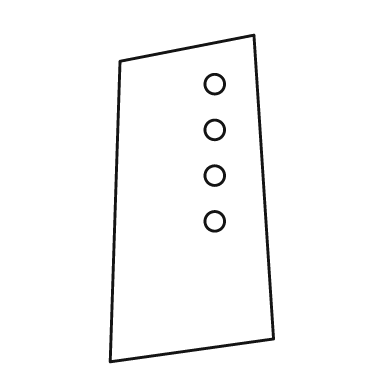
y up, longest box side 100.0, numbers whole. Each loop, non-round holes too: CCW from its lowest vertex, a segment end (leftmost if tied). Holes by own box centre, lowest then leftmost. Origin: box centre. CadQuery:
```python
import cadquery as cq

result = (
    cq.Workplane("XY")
    .moveTo(-25.0, -50.0)
    .lineTo(25.0, -43.0)
    .lineTo(19.0, 50.0)
    .lineTo(-22.0, 42.0)
    .close()
    .moveTo(7.0, -7.0)
    .circle(3.0)
    .moveTo(7.0, 7.0)
    .circle(3.0)
    .moveTo(7.0, 21.0)
    .circle(3.0)
    .moveTo(7.0, 35.0)
    .circle(3.0)
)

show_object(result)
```